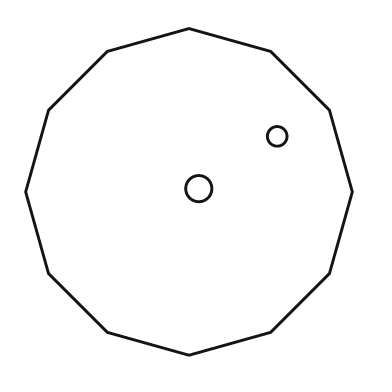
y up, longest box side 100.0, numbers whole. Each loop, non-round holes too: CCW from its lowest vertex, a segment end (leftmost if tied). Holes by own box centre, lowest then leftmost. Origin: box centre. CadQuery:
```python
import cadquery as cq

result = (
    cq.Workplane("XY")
    .moveTo(0.0, -50.0)
    .lineTo(25.0, -43.0)
    .lineTo(43.0, -25.0)
    .lineTo(50.0, 0.0)
    .lineTo(43.0, 25.0)
    .lineTo(25.0, 43.0)
    .lineTo(0.0, 50.0)
    .lineTo(-25.0, 43.0)
    .lineTo(-43.0, 25.0)
    .lineTo(-50.0, 0.0)
    .lineTo(-43.0, -25.0)
    .lineTo(-25.0, -43.0)
    .close()
    .moveTo(3.0, 1.0)
    .circle(4.0)
    .moveTo(27.0, 17.0)
    .circle(3.0)
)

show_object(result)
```